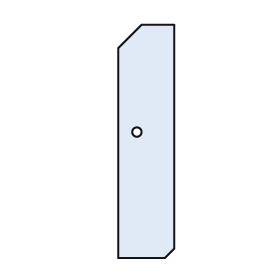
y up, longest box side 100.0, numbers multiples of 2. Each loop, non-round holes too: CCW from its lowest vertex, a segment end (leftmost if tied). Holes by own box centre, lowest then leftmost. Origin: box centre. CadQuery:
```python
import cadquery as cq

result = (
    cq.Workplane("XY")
    .moveTo(-12.0, -50.0)
    .lineTo(8.0, -50.0)
    .lineTo(12.0, -46.0)
    .lineTo(12.0, 50.0)
    .lineTo(-2.0, 50.0)
    .lineTo(-12.0, 40.0)
    .close()
    .moveTo(-4.0, 4.0)
    .circle(2.0)
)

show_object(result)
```